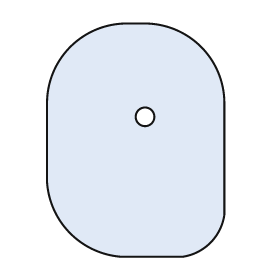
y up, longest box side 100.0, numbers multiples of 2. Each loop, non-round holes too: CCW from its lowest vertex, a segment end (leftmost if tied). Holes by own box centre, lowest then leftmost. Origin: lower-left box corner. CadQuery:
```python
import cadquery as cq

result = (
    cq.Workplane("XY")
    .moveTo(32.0, 0.0)
    .lineTo(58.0, 0.0)
    .threePointArc((70.0, 6.0), (76.0, 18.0))
    .lineTo(76.0, 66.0)
    .threePointArc((66.0, 90.0), (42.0, 100.0))
    .lineTo(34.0, 100.0)
    .threePointArc((10.0, 90.0), (0.0, 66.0))
    .lineTo(0.0, 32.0)
    .threePointArc((10.0, 10.0), (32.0, 0.0))
    .close()
    .moveTo(42.0, 60.0)
    .circle(4.0)
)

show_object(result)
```